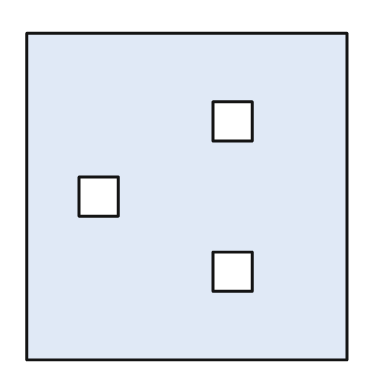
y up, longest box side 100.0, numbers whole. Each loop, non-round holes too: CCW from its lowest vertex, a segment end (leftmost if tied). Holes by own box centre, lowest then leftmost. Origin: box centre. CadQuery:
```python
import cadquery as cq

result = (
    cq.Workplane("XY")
    .moveTo(-49.0, -50.0)
    .lineTo(49.0, -50.0)
    .lineTo(49.0, 50.0)
    .lineTo(-49.0, 50.0)
    .close()
    .moveTo(8.0, -29.0)
    .lineTo(20.0, -29.0)
    .lineTo(20.0, -17.0)
    .lineTo(8.0, -17.0)
    .close()
    .moveTo(-33.0, -6.0)
    .lineTo(-21.0, -6.0)
    .lineTo(-21.0, 6.0)
    .lineTo(-33.0, 6.0)
    .close()
    .moveTo(8.0, 17.0)
    .lineTo(20.0, 17.0)
    .lineTo(20.0, 29.0)
    .lineTo(8.0, 29.0)
    .close()
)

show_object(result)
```